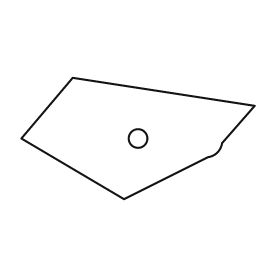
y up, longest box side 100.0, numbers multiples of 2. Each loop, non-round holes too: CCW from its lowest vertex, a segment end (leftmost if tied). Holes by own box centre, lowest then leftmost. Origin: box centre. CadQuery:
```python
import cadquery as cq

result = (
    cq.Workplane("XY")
    .moveTo(-6.0, -26.0)
    .lineTo(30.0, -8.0)
    .threePointArc((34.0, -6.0), (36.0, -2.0))
    .lineTo(50.0, 14.0)
    .lineTo(-28.0, 26.0)
    .lineTo(-50.0, 0.0)
    .close()
    .moveTo(0.0, 0.0)
    .circle(4.0)
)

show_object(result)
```